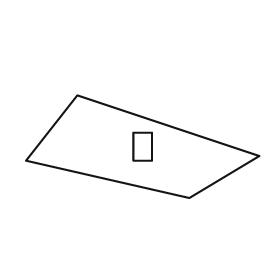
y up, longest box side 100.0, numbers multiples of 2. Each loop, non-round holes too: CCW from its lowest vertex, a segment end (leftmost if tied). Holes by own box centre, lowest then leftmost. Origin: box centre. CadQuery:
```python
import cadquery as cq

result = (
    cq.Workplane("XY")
    .moveTo(20.0, -22.0)
    .lineTo(50.0, -4.0)
    .lineTo(-28.0, 22.0)
    .lineTo(-50.0, -6.0)
    .close()
    .moveTo(-4.0, -6.0)
    .lineTo(4.0, -6.0)
    .lineTo(4.0, 6.0)
    .lineTo(-4.0, 6.0)
    .close()
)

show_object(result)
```